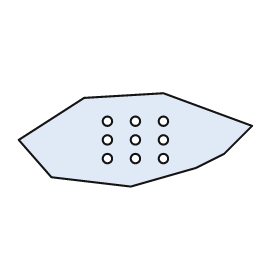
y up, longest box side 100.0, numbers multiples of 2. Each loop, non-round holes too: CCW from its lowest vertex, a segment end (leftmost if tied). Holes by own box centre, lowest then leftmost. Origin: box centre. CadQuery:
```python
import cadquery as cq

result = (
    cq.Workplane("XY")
    .moveTo(-2.0, -20.0)
    .lineTo(26.0, -12.0)
    .lineTo(38.0, -6.0)
    .lineTo(50.0, 6.0)
    .lineTo(12.0, 20.0)
    .lineTo(-22.0, 18.0)
    .lineTo(-50.0, 0.0)
    .lineTo(-36.0, -16.0)
    .close()
    .moveTo(-12.0, -8.0)
    .circle(2.0)
    .moveTo(0.0, -8.0)
    .circle(2.0)
    .moveTo(12.0, -8.0)
    .circle(2.0)
    .moveTo(-12.0, 0.0)
    .circle(2.0)
    .moveTo(0.0, 0.0)
    .circle(2.0)
    .moveTo(12.0, 0.0)
    .circle(2.0)
    .moveTo(-12.0, 8.0)
    .circle(2.0)
    .moveTo(0.0, 8.0)
    .circle(2.0)
    .moveTo(12.0, 8.0)
    .circle(2.0)
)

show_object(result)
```